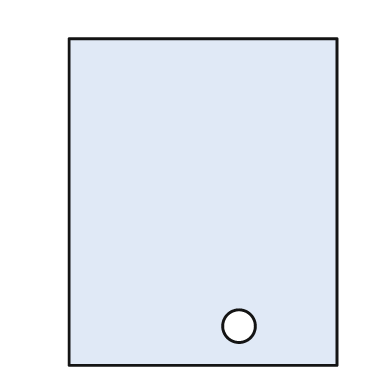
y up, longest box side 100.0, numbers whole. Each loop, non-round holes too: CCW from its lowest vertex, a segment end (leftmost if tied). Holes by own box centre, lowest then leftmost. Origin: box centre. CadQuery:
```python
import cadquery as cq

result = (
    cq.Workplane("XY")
    .moveTo(-41.0, -50.0)
    .lineTo(41.0, -50.0)
    .lineTo(41.0, 50.0)
    .lineTo(-41.0, 50.0)
    .close()
    .moveTo(11.0, -38.0)
    .circle(5.0)
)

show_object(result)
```